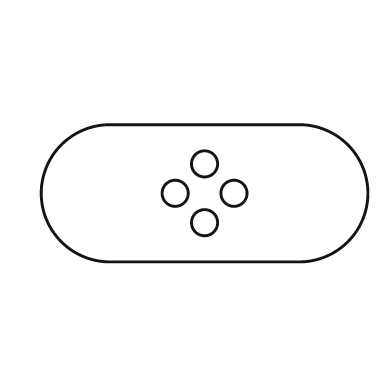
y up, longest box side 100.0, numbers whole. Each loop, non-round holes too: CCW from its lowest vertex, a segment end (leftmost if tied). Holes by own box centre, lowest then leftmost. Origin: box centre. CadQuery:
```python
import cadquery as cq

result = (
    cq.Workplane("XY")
    .moveTo(-29.0, -21.0)
    .lineTo(29.0, -21.0)
    .threePointArc((50.0, 0.0), (29.0, 21.0))
    .lineTo(-29.0, 21.0)
    .threePointArc((-50.0, 0.0), (-29.0, -21.0))
    .close()
    .moveTo(0.0, -9.0)
    .circle(4.0)
    .moveTo(-9.0, 0.0)
    .circle(4.0)
    .moveTo(9.0, 0.0)
    .circle(4.0)
    .moveTo(0.0, 9.0)
    .circle(4.0)
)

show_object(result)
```